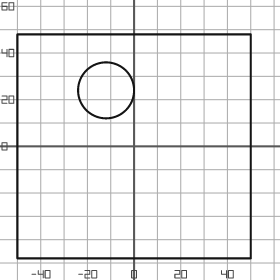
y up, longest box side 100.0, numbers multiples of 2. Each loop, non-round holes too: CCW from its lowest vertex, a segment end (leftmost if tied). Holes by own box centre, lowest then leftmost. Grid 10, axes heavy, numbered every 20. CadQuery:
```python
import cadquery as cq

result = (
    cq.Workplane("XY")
    .moveTo(-50.0, -48.0)
    .lineTo(50.0, -48.0)
    .lineTo(50.0, 48.0)
    .lineTo(-50.0, 48.0)
    .close()
    .moveTo(-12.0, 24.0)
    .circle(12.0)
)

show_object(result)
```